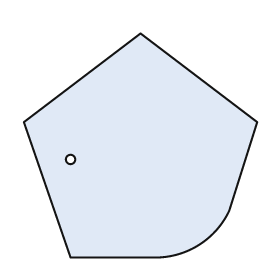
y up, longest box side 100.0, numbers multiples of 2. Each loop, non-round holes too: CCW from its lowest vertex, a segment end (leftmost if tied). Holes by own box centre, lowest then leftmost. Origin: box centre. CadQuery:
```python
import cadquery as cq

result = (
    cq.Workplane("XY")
    .moveTo(-30.0, -48.0)
    .lineTo(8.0, -48.0)
    .threePointArc((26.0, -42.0), (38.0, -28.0))
    .lineTo(50.0, 10.0)
    .lineTo(0.0, 48.0)
    .lineTo(-50.0, 10.0)
    .close()
    .moveTo(-30.0, -6.0)
    .circle(2.0)
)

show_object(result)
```